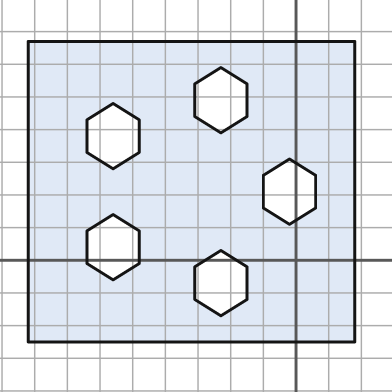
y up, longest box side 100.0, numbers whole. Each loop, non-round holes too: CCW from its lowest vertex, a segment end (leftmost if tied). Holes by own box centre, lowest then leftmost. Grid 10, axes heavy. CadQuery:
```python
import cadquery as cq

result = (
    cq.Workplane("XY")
    .moveTo(-82.0, -25.0)
    .lineTo(18.0, -25.0)
    .lineTo(18.0, 67.0)
    .lineTo(-82.0, 67.0)
    .close()
    .moveTo(-23.0, -17.0)
    .lineTo(-15.0, -12.0)
    .lineTo(-15.0, -2.0)
    .lineTo(-23.0, 3.0)
    .lineTo(-31.0, -2.0)
    .lineTo(-31.0, -12.0)
    .close()
    .moveTo(-56.0, -6.0)
    .lineTo(-48.0, -1.0)
    .lineTo(-48.0, 9.0)
    .lineTo(-56.0, 14.0)
    .lineTo(-64.0, 9.0)
    .lineTo(-64.0, -1.0)
    .close()
    .moveTo(-2.0, 11.0)
    .lineTo(6.0, 16.0)
    .lineTo(6.0, 26.0)
    .lineTo(-2.0, 31.0)
    .lineTo(-10.0, 26.0)
    .lineTo(-10.0, 16.0)
    .close()
    .moveTo(-56.0, 28.0)
    .lineTo(-48.0, 33.0)
    .lineTo(-48.0, 43.0)
    .lineTo(-56.0, 48.0)
    .lineTo(-64.0, 43.0)
    .lineTo(-64.0, 33.0)
    .close()
    .moveTo(-23.0, 39.0)
    .lineTo(-15.0, 44.0)
    .lineTo(-15.0, 54.0)
    .lineTo(-23.0, 59.0)
    .lineTo(-31.0, 54.0)
    .lineTo(-31.0, 44.0)
    .close()
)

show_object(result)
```